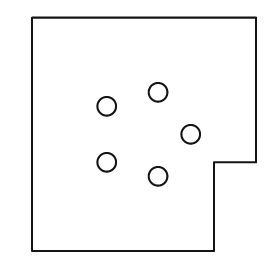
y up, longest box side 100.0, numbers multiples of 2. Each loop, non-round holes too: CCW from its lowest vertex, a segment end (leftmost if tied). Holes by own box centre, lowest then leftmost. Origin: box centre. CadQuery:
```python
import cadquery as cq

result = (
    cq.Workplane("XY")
    .moveTo(-48.0, -50.0)
    .lineTo(30.0, -50.0)
    .lineTo(30.0, -12.0)
    .lineTo(48.0, -12.0)
    .lineTo(48.0, 50.0)
    .lineTo(-48.0, 50.0)
    .close()
    .moveTo(6.0, -18.0)
    .circle(4.0)
    .moveTo(-16.0, -12.0)
    .circle(4.0)
    .moveTo(20.0, 0.0)
    .circle(4.0)
    .moveTo(-16.0, 12.0)
    .circle(4.0)
    .moveTo(6.0, 18.0)
    .circle(4.0)
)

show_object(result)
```